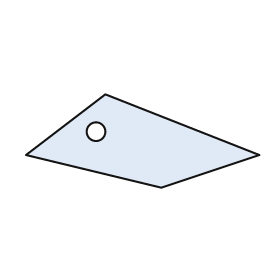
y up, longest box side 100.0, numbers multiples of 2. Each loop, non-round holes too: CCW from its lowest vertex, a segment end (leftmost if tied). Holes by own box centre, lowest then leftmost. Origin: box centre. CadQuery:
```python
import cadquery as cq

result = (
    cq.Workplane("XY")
    .moveTo(8.0, -20.0)
    .lineTo(50.0, -6.0)
    .lineTo(-16.0, 20.0)
    .lineTo(-50.0, -6.0)
    .close()
    .moveTo(-20.0, 4.0)
    .circle(4.0)
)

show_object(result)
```